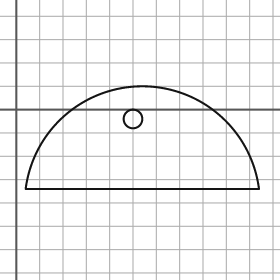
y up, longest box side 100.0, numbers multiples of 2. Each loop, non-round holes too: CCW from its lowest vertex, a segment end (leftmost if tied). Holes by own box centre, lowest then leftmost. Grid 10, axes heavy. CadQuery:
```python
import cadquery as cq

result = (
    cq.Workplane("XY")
    .moveTo(4.0, -34.0)
    .lineTo(104.0, -34.0)
    .threePointArc((54.0, 10.0), (4.0, -34.0))
    .close()
    .moveTo(50.0, -4.0)
    .circle(4.0)
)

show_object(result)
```